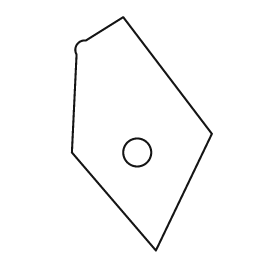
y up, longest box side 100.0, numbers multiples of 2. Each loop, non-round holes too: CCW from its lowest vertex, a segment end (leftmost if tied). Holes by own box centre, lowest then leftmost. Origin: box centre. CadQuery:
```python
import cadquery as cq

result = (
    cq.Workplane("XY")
    .moveTo(6.0, -50.0)
    .lineTo(30.0, 0.0)
    .lineTo(-8.0, 50.0)
    .lineTo(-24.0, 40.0)
    .threePointArc((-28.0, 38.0), (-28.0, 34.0))
    .lineTo(-30.0, -8.0)
    .close()
    .moveTo(-2.0, -8.0)
    .circle(6.0)
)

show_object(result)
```